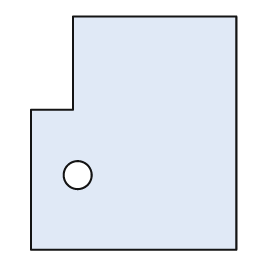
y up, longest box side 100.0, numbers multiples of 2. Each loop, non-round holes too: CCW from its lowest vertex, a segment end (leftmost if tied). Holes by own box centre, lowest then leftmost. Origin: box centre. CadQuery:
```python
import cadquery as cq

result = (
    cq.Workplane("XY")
    .moveTo(-44.0, -50.0)
    .lineTo(44.0, -50.0)
    .lineTo(44.0, 50.0)
    .lineTo(-26.0, 50.0)
    .lineTo(-26.0, 10.0)
    .lineTo(-44.0, 10.0)
    .close()
    .moveTo(-24.0, -18.0)
    .circle(6.0)
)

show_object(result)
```